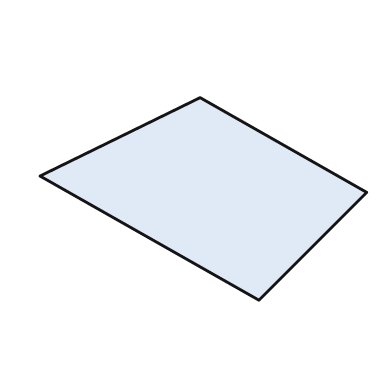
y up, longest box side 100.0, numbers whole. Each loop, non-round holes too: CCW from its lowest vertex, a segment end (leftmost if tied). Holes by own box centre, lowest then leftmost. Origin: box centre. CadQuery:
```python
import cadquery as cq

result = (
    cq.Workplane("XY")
    .moveTo(17.0, -31.0)
    .lineTo(50.0, 2.0)
    .lineTo(-1.0, 31.0)
    .lineTo(-50.0, 7.0)
    .close()
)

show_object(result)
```